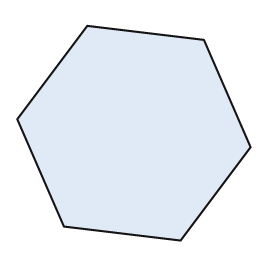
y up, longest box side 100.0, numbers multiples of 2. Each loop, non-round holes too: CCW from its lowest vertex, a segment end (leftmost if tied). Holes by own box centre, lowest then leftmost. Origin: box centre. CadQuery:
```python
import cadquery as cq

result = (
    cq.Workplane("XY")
    .moveTo(20.0, -46.0)
    .lineTo(50.0, -6.0)
    .lineTo(30.0, 40.0)
    .lineTo(-20.0, 46.0)
    .lineTo(-50.0, 6.0)
    .lineTo(-30.0, -40.0)
    .close()
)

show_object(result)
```